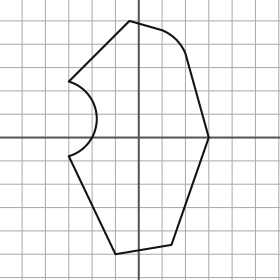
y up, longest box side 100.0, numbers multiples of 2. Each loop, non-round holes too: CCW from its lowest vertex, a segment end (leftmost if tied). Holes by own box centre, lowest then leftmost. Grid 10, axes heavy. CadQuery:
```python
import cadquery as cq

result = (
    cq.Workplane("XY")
    .moveTo(-10.0, -50.0)
    .lineTo(14.0, -46.0)
    .lineTo(30.0, 0.0)
    .lineTo(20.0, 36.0)
    .threePointArc((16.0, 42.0), (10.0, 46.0))
    .lineTo(-4.0, 50.0)
    .lineTo(-30.0, 24.0)
    .threePointArc((-18.0, 8.0), (-30.0, -8.0))
    .close()
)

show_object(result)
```